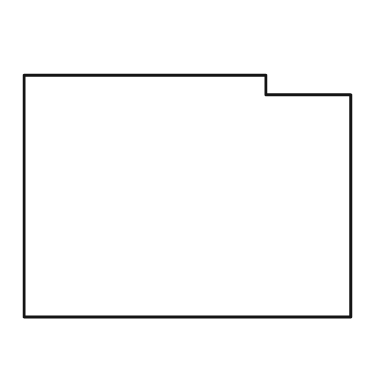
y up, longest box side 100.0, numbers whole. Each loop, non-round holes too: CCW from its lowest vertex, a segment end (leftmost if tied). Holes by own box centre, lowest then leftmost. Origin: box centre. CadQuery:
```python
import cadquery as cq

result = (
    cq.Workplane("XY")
    .moveTo(-50.0, -37.0)
    .lineTo(50.0, -37.0)
    .lineTo(50.0, 31.0)
    .lineTo(24.0, 31.0)
    .lineTo(24.0, 37.0)
    .lineTo(-50.0, 37.0)
    .close()
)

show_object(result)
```